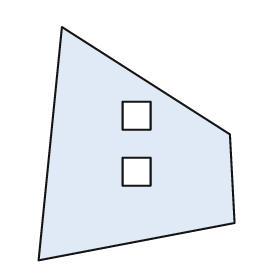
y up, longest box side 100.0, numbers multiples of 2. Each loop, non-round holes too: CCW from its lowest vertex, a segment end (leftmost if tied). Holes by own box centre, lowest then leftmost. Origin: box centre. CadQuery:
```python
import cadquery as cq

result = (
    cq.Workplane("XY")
    .moveTo(-42.0, -50.0)
    .lineTo(42.0, -34.0)
    .lineTo(40.0, 4.0)
    .lineTo(-32.0, 50.0)
    .close()
    .moveTo(-6.0, -18.0)
    .lineTo(6.0, -18.0)
    .lineTo(6.0, -6.0)
    .lineTo(-6.0, -6.0)
    .close()
    .moveTo(-6.0, 6.0)
    .lineTo(6.0, 6.0)
    .lineTo(6.0, 18.0)
    .lineTo(-6.0, 18.0)
    .close()
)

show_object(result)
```